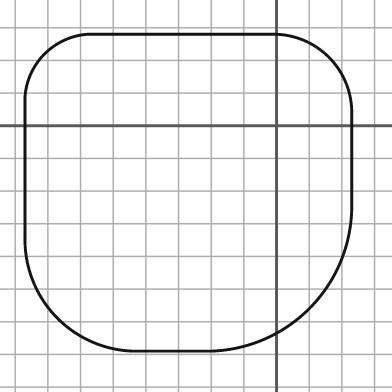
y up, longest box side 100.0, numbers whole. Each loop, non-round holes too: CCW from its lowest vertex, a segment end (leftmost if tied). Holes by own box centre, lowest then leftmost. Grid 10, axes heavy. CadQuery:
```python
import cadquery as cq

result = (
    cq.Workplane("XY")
    .moveTo(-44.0, -69.0)
    .lineTo(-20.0, -69.0)
    .threePointArc((10.0, -56.0), (23.0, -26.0))
    .lineTo(23.0, 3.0)
    .threePointArc((16.0, 21.0), (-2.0, 28.0))
    .lineTo(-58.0, 28.0)
    .threePointArc((-71.0, 22.0), (-77.0, 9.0))
    .lineTo(-77.0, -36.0)
    .threePointArc((-67.0, -59.0), (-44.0, -69.0))
    .close()
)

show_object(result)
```